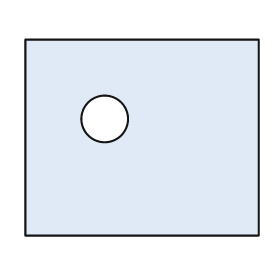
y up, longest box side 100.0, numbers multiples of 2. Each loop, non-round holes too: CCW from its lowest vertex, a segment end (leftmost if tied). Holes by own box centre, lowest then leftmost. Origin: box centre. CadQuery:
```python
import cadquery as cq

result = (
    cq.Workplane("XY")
    .moveTo(-50.0, -42.0)
    .lineTo(50.0, -42.0)
    .lineTo(50.0, 42.0)
    .lineTo(-50.0, 42.0)
    .close()
    .moveTo(-16.0, 8.0)
    .circle(10.0)
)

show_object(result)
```